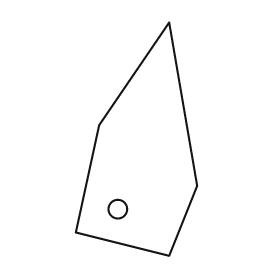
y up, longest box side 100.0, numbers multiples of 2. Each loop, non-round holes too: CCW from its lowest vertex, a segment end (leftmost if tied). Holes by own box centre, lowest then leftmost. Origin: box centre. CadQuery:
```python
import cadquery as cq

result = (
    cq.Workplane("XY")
    .moveTo(14.0, -50.0)
    .lineTo(26.0, -20.0)
    .lineTo(14.0, 50.0)
    .lineTo(-16.0, 6.0)
    .lineTo(-26.0, -40.0)
    .close()
    .moveTo(-8.0, -30.0)
    .circle(4.0)
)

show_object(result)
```